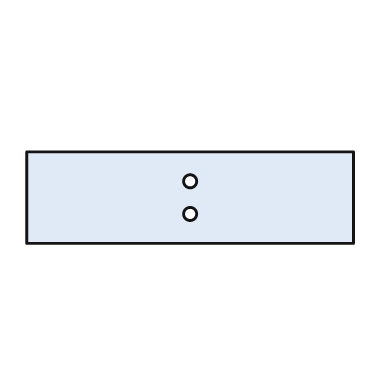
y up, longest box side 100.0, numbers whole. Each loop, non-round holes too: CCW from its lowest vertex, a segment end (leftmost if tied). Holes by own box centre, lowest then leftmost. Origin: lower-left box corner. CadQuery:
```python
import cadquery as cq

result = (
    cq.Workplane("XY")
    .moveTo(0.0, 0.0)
    .lineTo(100.0, 0.0)
    .lineTo(100.0, 28.0)
    .lineTo(0.0, 28.0)
    .close()
    .moveTo(50.0, 9.0)
    .circle(2.0)
    .moveTo(50.0, 19.0)
    .circle(2.0)
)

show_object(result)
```